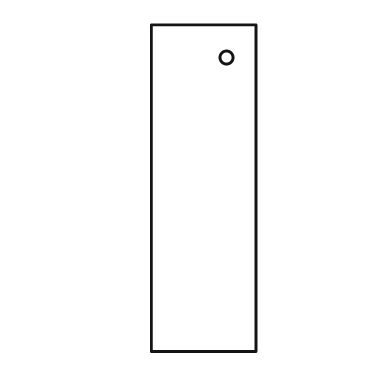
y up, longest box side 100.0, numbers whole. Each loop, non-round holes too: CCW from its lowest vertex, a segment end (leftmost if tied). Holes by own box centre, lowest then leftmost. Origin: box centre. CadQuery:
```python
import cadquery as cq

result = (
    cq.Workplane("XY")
    .moveTo(-16.0, -50.0)
    .lineTo(16.0, -50.0)
    .lineTo(16.0, 50.0)
    .lineTo(-16.0, 50.0)
    .close()
    .moveTo(7.0, 40.0)
    .circle(2.0)
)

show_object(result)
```